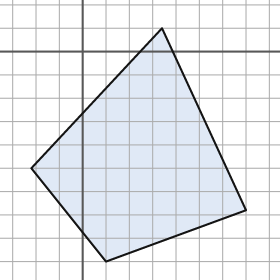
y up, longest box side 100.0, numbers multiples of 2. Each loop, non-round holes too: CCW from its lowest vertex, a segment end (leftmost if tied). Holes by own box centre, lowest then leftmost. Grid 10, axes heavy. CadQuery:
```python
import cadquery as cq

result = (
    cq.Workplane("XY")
    .moveTo(10.0, -90.0)
    .lineTo(70.0, -68.0)
    .lineTo(34.0, 10.0)
    .lineTo(-22.0, -50.0)
    .close()
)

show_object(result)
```